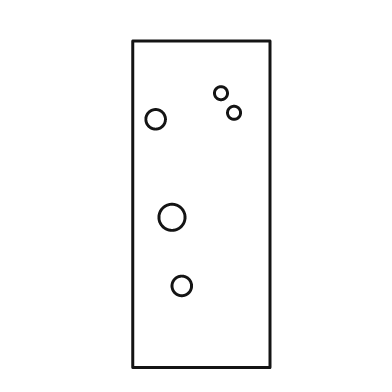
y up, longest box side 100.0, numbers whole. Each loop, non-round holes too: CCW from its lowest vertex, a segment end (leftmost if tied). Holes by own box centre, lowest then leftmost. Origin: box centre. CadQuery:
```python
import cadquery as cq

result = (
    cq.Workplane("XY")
    .moveTo(-21.0, -50.0)
    .lineTo(21.0, -50.0)
    .lineTo(21.0, 50.0)
    .lineTo(-21.0, 50.0)
    .close()
    .moveTo(-6.0, -25.0)
    .circle(3.0)
    .moveTo(-9.0, -4.0)
    .circle(4.0)
    .moveTo(-14.0, 26.0)
    .circle(3.0)
    .moveTo(10.0, 28.0)
    .circle(2.0)
    .moveTo(6.0, 34.0)
    .circle(2.0)
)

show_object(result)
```